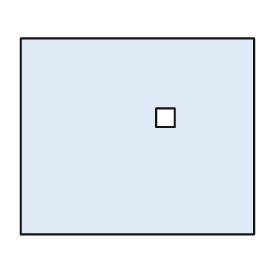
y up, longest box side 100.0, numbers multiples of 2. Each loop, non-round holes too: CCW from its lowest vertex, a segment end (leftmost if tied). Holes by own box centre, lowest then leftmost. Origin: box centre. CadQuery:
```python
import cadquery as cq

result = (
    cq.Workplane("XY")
    .moveTo(-50.0, -42.0)
    .lineTo(50.0, -42.0)
    .lineTo(50.0, 42.0)
    .lineTo(-50.0, 42.0)
    .close()
    .moveTo(8.0, 4.0)
    .lineTo(16.0, 4.0)
    .lineTo(16.0, 12.0)
    .lineTo(8.0, 12.0)
    .close()
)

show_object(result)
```